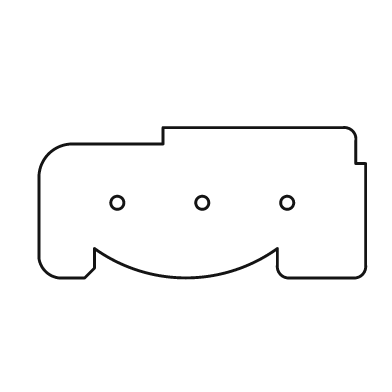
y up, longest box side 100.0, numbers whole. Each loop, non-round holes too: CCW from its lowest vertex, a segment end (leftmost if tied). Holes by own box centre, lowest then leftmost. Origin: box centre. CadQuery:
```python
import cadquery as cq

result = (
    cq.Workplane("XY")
    .moveTo(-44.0, -23.0)
    .lineTo(-36.0, -23.0)
    .lineTo(-33.0, -20.0)
    .lineTo(-33.0, -14.0)
    .threePointArc((-5.0, -23.0), (23.0, -14.0))
    .lineTo(23.0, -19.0)
    .threePointArc((24.0, -22.0), (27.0, -23.0))
    .lineTo(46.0, -23.0)
    .threePointArc((49.0, -22.0), (50.0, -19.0))
    .lineTo(50.0, 12.0)
    .lineTo(47.0, 12.0)
    .lineTo(47.0, 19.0)
    .threePointArc((46.0, 22.0), (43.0, 23.0))
    .lineTo(-12.0, 23.0)
    .lineTo(-12.0, 18.0)
    .lineTo(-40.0, 18.0)
    .threePointArc((-47.0, 15.0), (-50.0, 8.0))
    .lineTo(-50.0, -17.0)
    .threePointArc((-48.0, -21.0), (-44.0, -23.0))
    .close()
    .moveTo(-26.0, 0.0)
    .circle(2.0)
    .moveTo(0.0, 0.0)
    .circle(2.0)
    .moveTo(26.0, 0.0)
    .circle(2.0)
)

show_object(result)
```